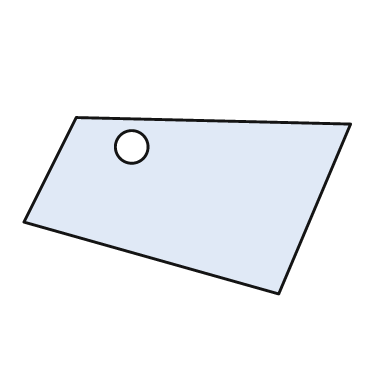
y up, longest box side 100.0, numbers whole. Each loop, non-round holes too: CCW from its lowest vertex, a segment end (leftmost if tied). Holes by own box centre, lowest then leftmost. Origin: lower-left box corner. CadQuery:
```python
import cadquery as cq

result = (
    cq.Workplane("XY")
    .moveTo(78.0, 0.0)
    .lineTo(100.0, 52.0)
    .lineTo(16.0, 54.0)
    .lineTo(0.0, 22.0)
    .close()
    .moveTo(33.0, 45.0)
    .circle(5.0)
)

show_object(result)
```